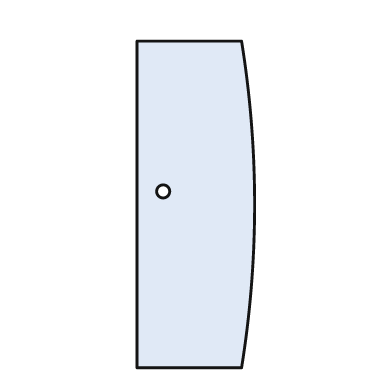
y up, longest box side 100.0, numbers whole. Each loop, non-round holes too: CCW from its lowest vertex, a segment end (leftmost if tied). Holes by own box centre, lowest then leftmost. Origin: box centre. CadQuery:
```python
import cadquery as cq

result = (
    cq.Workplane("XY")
    .moveTo(-18.0, -50.0)
    .lineTo(14.0, -50.0)
    .threePointArc((18.0, 0.0), (14.0, 50.0))
    .lineTo(-18.0, 50.0)
    .close()
    .moveTo(-10.0, 4.0)
    .circle(2.0)
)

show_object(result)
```